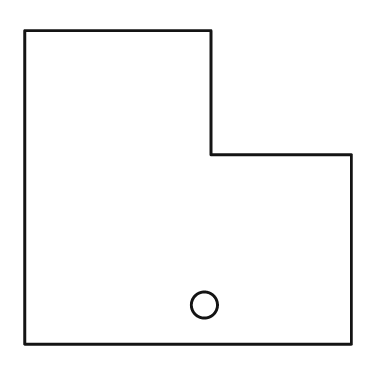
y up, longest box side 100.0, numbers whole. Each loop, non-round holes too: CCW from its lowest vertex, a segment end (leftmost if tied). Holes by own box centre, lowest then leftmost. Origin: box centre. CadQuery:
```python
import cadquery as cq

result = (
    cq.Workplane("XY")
    .moveTo(-50.0, -48.0)
    .lineTo(50.0, -48.0)
    .lineTo(50.0, 10.0)
    .lineTo(7.0, 10.0)
    .lineTo(7.0, 48.0)
    .lineTo(-50.0, 48.0)
    .close()
    .moveTo(5.0, -36.0)
    .circle(4.0)
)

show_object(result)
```